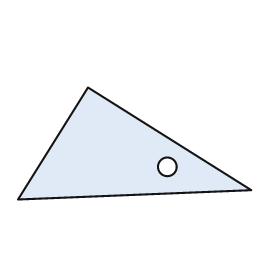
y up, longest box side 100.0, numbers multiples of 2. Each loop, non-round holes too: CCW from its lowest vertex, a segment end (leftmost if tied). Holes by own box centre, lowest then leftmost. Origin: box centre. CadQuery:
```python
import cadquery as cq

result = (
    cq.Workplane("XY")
    .moveTo(-50.0, -24.0)
    .lineTo(50.0, -20.0)
    .lineTo(-20.0, 24.0)
    .close()
    .moveTo(14.0, -10.0)
    .circle(4.0)
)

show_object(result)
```